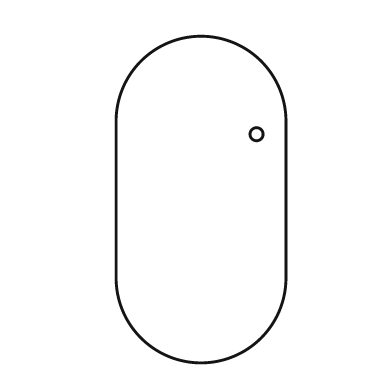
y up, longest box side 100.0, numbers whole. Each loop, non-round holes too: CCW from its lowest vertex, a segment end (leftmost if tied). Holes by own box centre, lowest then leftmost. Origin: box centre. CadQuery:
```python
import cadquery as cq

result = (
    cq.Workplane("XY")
    .moveTo(-26.0, -24.0)
    .threePointArc((0.0, -50.0), (26.0, -24.0))
    .lineTo(26.0, 24.0)
    .threePointArc((0.0, 50.0), (-26.0, 24.0))
    .close()
    .moveTo(17.0, 20.0)
    .circle(2.0)
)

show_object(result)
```